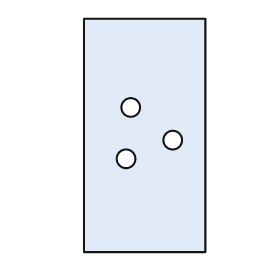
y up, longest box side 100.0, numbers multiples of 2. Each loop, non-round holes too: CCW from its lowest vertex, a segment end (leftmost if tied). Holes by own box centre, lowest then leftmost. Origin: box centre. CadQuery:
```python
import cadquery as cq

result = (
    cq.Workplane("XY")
    .moveTo(-26.0, -50.0)
    .lineTo(26.0, -50.0)
    .lineTo(26.0, 50.0)
    .lineTo(-26.0, 50.0)
    .close()
    .moveTo(-8.0, -10.0)
    .circle(4.0)
    .moveTo(12.0, -2.0)
    .circle(4.0)
    .moveTo(-6.0, 12.0)
    .circle(4.0)
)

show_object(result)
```